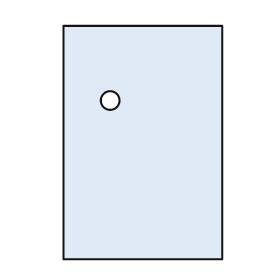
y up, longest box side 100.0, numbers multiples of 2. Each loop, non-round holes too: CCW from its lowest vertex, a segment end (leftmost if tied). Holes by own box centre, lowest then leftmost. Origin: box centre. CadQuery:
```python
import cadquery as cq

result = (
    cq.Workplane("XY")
    .moveTo(-34.0, -50.0)
    .lineTo(34.0, -50.0)
    .lineTo(34.0, 50.0)
    .lineTo(-34.0, 50.0)
    .close()
    .moveTo(-14.0, 18.0)
    .circle(4.0)
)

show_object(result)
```